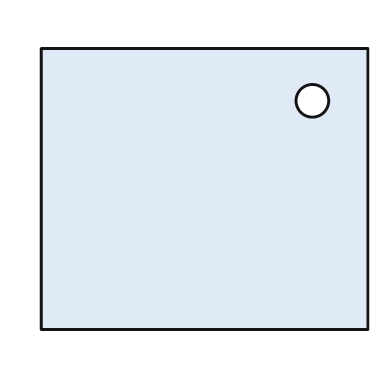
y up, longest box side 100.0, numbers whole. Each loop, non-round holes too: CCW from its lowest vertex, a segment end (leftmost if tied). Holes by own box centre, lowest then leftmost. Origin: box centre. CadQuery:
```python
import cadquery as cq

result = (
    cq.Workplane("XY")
    .moveTo(-50.0, -43.0)
    .lineTo(50.0, -43.0)
    .lineTo(50.0, 43.0)
    .lineTo(-50.0, 43.0)
    .close()
    .moveTo(33.0, 27.0)
    .circle(5.0)
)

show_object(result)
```